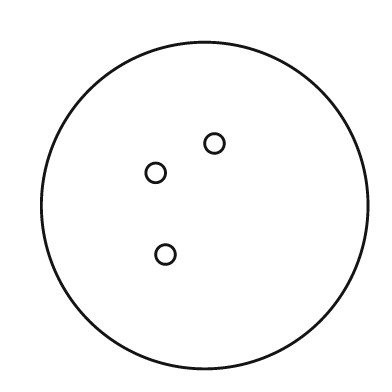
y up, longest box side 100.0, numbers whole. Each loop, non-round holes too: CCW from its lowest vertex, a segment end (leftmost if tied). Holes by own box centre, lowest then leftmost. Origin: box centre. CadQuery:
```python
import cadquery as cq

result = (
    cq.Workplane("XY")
    .moveTo(0.0, 0.0)
    .circle(50.0)
    .moveTo(-12.0, -15.0)
    .circle(3.0)
    .moveTo(-15.0, 10.0)
    .circle(3.0)
    .moveTo(3.0, 19.0)
    .circle(3.0)
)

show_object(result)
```